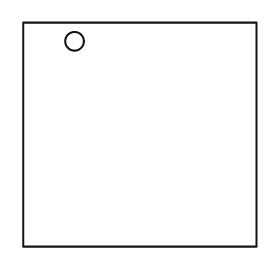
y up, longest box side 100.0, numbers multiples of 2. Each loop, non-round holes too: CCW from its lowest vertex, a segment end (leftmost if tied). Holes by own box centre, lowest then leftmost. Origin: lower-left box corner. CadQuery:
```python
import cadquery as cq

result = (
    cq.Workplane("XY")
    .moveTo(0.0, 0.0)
    .lineTo(100.0, 0.0)
    .lineTo(100.0, 96.0)
    .lineTo(0.0, 96.0)
    .close()
    .moveTo(22.0, 88.0)
    .circle(4.0)
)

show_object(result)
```